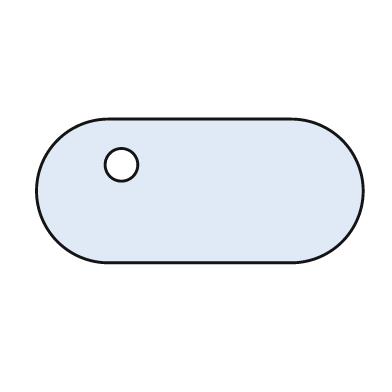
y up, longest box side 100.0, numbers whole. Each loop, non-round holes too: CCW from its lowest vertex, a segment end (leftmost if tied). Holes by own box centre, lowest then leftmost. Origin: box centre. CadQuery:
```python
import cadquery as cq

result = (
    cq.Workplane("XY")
    .moveTo(-28.0, -22.0)
    .lineTo(28.0, -22.0)
    .threePointArc((50.0, 0.0), (28.0, 22.0))
    .lineTo(-28.0, 22.0)
    .threePointArc((-50.0, 0.0), (-28.0, -22.0))
    .close()
    .moveTo(-24.0, 8.0)
    .circle(5.0)
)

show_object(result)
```